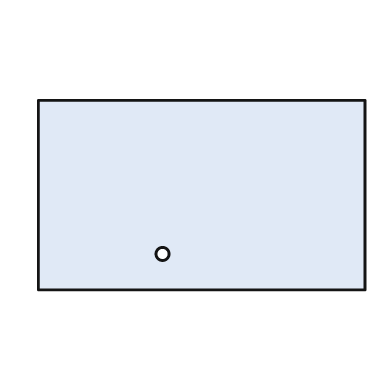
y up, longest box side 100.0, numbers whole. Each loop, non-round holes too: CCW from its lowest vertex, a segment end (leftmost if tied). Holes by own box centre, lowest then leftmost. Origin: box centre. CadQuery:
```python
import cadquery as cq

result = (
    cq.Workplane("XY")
    .moveTo(-50.0, -29.0)
    .lineTo(50.0, -29.0)
    .lineTo(50.0, 29.0)
    .lineTo(-50.0, 29.0)
    .close()
    .moveTo(-12.0, -18.0)
    .circle(2.0)
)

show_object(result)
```